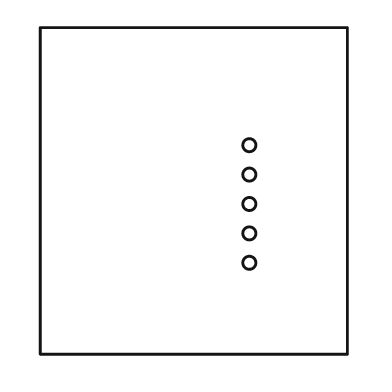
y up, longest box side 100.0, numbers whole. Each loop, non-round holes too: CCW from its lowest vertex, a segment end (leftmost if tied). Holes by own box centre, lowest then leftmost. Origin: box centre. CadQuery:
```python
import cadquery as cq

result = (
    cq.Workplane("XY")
    .moveTo(-47.0, -50.0)
    .lineTo(47.0, -50.0)
    .lineTo(47.0, 50.0)
    .lineTo(-47.0, 50.0)
    .close()
    .moveTo(17.0, -22.0)
    .circle(2.0)
    .moveTo(17.0, -13.0)
    .circle(2.0)
    .moveTo(17.0, -4.0)
    .circle(2.0)
    .moveTo(17.0, 5.0)
    .circle(2.0)
    .moveTo(17.0, 14.0)
    .circle(2.0)
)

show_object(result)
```